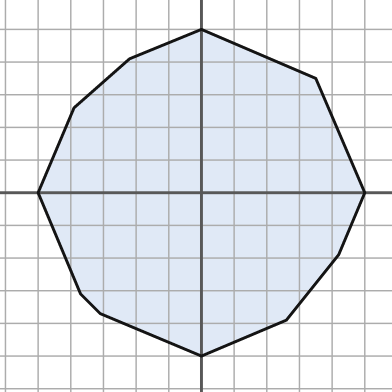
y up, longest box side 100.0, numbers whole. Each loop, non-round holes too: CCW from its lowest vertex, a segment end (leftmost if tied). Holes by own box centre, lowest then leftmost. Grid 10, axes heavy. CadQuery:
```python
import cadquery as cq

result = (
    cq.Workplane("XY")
    .moveTo(0.0, -50.0)
    .lineTo(26.0, -39.0)
    .lineTo(42.0, -19.0)
    .lineTo(50.0, 0.0)
    .lineTo(35.0, 35.0)
    .lineTo(0.0, 50.0)
    .lineTo(-22.0, 41.0)
    .lineTo(-39.0, 26.0)
    .lineTo(-50.0, 0.0)
    .lineTo(-37.0, -31.0)
    .lineTo(-31.0, -37.0)
    .close()
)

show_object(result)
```